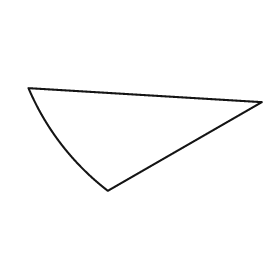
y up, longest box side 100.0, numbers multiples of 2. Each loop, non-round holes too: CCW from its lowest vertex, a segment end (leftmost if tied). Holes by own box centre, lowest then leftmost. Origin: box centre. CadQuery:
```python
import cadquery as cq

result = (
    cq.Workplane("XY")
    .moveTo(-16.0, -22.0)
    .lineTo(50.0, 16.0)
    .lineTo(-50.0, 22.0)
    .threePointArc((-36.0, -2.0), (-16.0, -22.0))
    .close()
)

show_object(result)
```